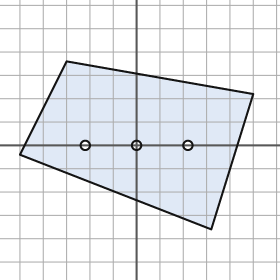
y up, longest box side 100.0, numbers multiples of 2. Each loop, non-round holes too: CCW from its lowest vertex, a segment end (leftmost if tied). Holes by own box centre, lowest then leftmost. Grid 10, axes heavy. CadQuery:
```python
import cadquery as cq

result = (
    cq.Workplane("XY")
    .moveTo(32.0, -36.0)
    .lineTo(50.0, 22.0)
    .lineTo(-30.0, 36.0)
    .lineTo(-50.0, -4.0)
    .close()
    .moveTo(-22.0, 0.0)
    .circle(2.0)
    .moveTo(0.0, 0.0)
    .circle(2.0)
    .moveTo(22.0, 0.0)
    .circle(2.0)
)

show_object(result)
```